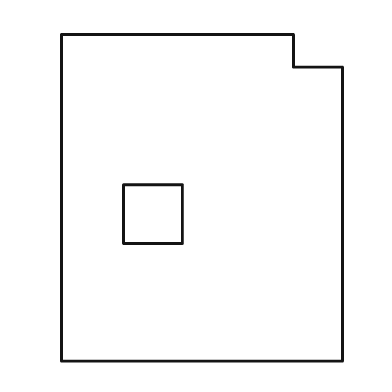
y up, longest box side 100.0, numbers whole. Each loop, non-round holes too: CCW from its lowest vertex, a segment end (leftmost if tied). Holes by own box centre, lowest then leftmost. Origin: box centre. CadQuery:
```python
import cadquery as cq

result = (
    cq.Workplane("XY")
    .moveTo(-43.0, -50.0)
    .lineTo(43.0, -50.0)
    .lineTo(43.0, 40.0)
    .lineTo(28.0, 40.0)
    .lineTo(28.0, 50.0)
    .lineTo(-43.0, 50.0)
    .close()
    .moveTo(-24.0, -14.0)
    .lineTo(-6.0, -14.0)
    .lineTo(-6.0, 4.0)
    .lineTo(-24.0, 4.0)
    .close()
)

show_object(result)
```